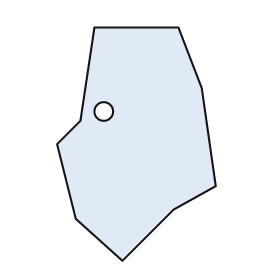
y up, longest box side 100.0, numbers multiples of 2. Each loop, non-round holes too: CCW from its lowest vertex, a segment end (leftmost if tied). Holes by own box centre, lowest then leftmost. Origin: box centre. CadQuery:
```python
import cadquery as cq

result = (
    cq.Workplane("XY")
    .moveTo(-6.0, -50.0)
    .lineTo(16.0, -28.0)
    .lineTo(34.0, -18.0)
    .lineTo(28.0, 24.0)
    .lineTo(18.0, 50.0)
    .lineTo(-18.0, 50.0)
    .lineTo(-24.0, 10.0)
    .lineTo(-34.0, 0.0)
    .lineTo(-26.0, -32.0)
    .close()
    .moveTo(-14.0, 14.0)
    .circle(4.0)
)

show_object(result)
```